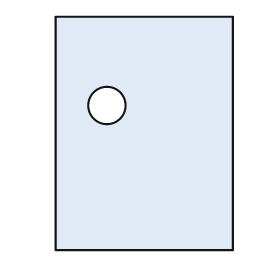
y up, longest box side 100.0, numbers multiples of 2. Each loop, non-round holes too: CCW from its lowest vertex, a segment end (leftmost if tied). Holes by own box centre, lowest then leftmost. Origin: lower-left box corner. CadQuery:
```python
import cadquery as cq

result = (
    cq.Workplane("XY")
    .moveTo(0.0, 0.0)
    .lineTo(76.0, 0.0)
    .lineTo(76.0, 100.0)
    .lineTo(0.0, 100.0)
    .close()
    .moveTo(22.0, 62.0)
    .circle(8.0)
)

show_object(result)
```